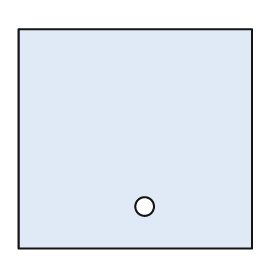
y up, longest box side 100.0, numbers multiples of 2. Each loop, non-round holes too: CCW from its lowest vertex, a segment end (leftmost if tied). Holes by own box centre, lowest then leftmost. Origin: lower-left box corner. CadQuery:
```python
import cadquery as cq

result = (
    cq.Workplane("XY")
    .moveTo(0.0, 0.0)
    .lineTo(100.0, 0.0)
    .lineTo(100.0, 94.0)
    .lineTo(0.0, 94.0)
    .close()
    .moveTo(54.0, 18.0)
    .circle(4.0)
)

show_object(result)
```